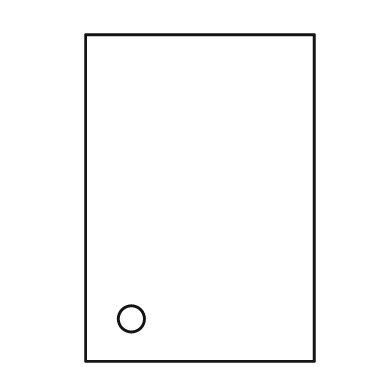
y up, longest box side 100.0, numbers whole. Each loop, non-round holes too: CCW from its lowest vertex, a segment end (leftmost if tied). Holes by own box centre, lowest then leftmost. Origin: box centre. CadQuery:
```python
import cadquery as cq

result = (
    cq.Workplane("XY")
    .moveTo(-35.0, -50.0)
    .lineTo(35.0, -50.0)
    .lineTo(35.0, 50.0)
    .lineTo(-35.0, 50.0)
    .close()
    .moveTo(-21.0, -37.0)
    .circle(4.0)
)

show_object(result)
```